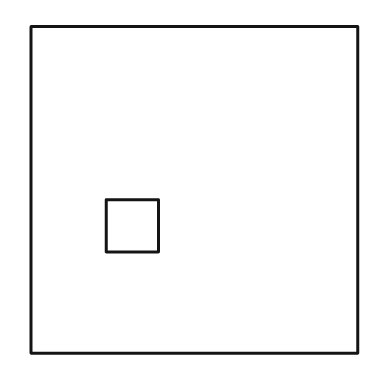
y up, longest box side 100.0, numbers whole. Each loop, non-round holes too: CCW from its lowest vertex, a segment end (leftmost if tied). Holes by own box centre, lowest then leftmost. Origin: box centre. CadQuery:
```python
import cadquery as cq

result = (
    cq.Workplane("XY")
    .moveTo(-50.0, -50.0)
    .lineTo(50.0, -50.0)
    .lineTo(50.0, 50.0)
    .lineTo(-50.0, 50.0)
    .close()
    .moveTo(-27.0, -19.0)
    .lineTo(-11.0, -19.0)
    .lineTo(-11.0, -3.0)
    .lineTo(-27.0, -3.0)
    .close()
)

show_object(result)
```